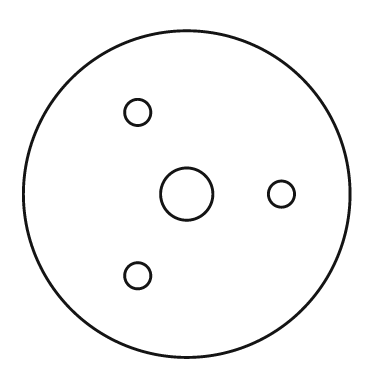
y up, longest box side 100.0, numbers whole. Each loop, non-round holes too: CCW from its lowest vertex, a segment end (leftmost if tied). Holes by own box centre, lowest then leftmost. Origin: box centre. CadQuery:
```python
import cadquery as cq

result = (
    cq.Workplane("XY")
    .moveTo(0.0, 0.0)
    .circle(50.0)
    .moveTo(-15.0, -25.0)
    .circle(4.0)
    .moveTo(0.0, 0.0)
    .circle(8.0)
    .moveTo(29.0, 0.0)
    .circle(4.0)
    .moveTo(-15.0, 25.0)
    .circle(4.0)
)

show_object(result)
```